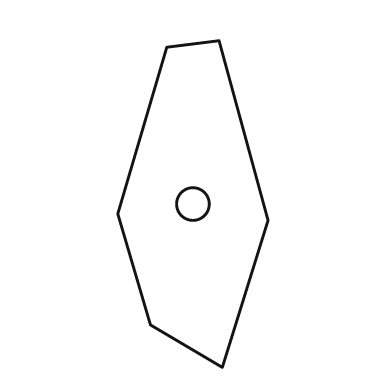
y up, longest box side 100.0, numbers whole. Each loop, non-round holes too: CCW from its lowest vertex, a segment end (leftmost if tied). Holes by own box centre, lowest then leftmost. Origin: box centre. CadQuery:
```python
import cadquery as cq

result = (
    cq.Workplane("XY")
    .moveTo(9.0, -50.0)
    .lineTo(23.0, -5.0)
    .lineTo(8.0, 50.0)
    .lineTo(-8.0, 48.0)
    .lineTo(-23.0, -3.0)
    .lineTo(-13.0, -37.0)
    .close()
    .moveTo(0.0, 0.0)
    .circle(5.0)
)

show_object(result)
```